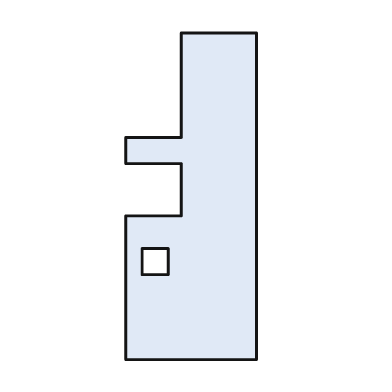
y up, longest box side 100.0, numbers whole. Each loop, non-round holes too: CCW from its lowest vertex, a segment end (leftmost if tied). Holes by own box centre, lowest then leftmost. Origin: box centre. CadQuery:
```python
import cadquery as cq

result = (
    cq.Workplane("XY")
    .moveTo(-20.0, -50.0)
    .lineTo(20.0, -50.0)
    .lineTo(20.0, 50.0)
    .lineTo(-3.0, 50.0)
    .lineTo(-3.0, 18.0)
    .lineTo(-20.0, 18.0)
    .lineTo(-20.0, 10.0)
    .lineTo(-3.0, 10.0)
    .lineTo(-3.0, -6.0)
    .lineTo(-20.0, -6.0)
    .close()
    .moveTo(-15.0, -24.0)
    .lineTo(-7.0, -24.0)
    .lineTo(-7.0, -16.0)
    .lineTo(-15.0, -16.0)
    .close()
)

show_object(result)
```